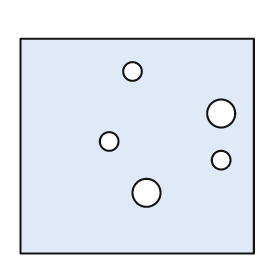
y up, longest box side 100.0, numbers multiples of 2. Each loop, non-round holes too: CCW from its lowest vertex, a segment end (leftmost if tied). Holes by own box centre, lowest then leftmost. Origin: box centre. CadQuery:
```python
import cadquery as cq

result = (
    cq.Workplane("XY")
    .moveTo(-50.0, -46.0)
    .lineTo(50.0, -46.0)
    .lineTo(50.0, 46.0)
    .lineTo(-50.0, 46.0)
    .close()
    .moveTo(4.0, -20.0)
    .circle(6.0)
    .moveTo(36.0, -6.0)
    .circle(4.0)
    .moveTo(-12.0, 2.0)
    .circle(4.0)
    .moveTo(36.0, 14.0)
    .circle(6.0)
    .moveTo(-2.0, 32.0)
    .circle(4.0)
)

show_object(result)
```